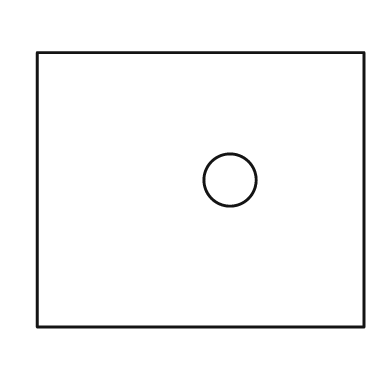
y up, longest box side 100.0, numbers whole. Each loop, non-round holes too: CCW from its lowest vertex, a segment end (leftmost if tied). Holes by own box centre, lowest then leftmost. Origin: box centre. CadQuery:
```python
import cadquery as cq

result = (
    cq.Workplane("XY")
    .moveTo(-50.0, -42.0)
    .lineTo(50.0, -42.0)
    .lineTo(50.0, 42.0)
    .lineTo(-50.0, 42.0)
    .close()
    .moveTo(9.0, 3.0)
    .circle(8.0)
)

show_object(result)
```